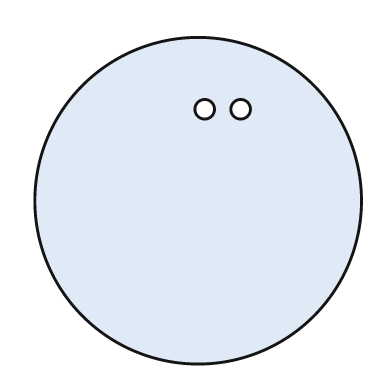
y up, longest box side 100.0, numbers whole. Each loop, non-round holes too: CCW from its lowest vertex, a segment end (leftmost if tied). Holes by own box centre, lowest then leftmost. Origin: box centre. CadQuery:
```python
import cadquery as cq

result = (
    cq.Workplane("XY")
    .moveTo(0.0, 0.0)
    .circle(50.0)
    .moveTo(2.0, 28.0)
    .circle(3.0)
    .moveTo(13.0, 28.0)
    .circle(3.0)
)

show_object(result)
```